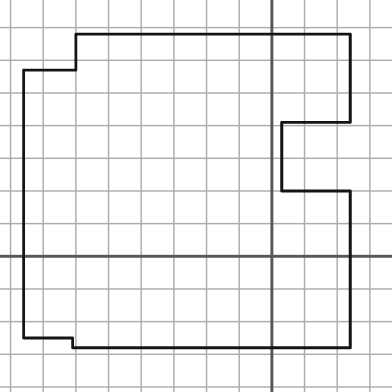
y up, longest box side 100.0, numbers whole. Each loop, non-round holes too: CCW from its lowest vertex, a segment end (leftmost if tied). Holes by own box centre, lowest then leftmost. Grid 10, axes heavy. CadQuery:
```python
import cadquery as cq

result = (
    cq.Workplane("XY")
    .moveTo(-61.0, -28.0)
    .lineTo(24.0, -28.0)
    .lineTo(24.0, 20.0)
    .lineTo(3.0, 20.0)
    .lineTo(3.0, 41.0)
    .lineTo(24.0, 41.0)
    .lineTo(24.0, 68.0)
    .lineTo(-60.0, 68.0)
    .lineTo(-60.0, 57.0)
    .lineTo(-76.0, 57.0)
    .lineTo(-76.0, -25.0)
    .lineTo(-61.0, -25.0)
    .close()
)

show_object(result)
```